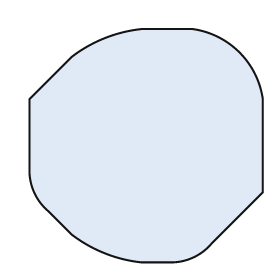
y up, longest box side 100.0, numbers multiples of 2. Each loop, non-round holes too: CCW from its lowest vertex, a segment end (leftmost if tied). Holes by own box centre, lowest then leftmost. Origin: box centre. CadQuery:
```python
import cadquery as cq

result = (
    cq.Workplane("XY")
    .moveTo(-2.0, -50.0)
    .lineTo(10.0, -50.0)
    .threePointArc((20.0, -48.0), (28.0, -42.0))
    .lineTo(50.0, -20.0)
    .lineTo(50.0, 20.0)
    .threePointArc((40.0, 40.0), (20.0, 50.0))
    .lineTo(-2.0, 50.0)
    .threePointArc((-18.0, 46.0), (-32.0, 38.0))
    .lineTo(-50.0, 20.0)
    .lineTo(-50.0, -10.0)
    .threePointArc((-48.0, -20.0), (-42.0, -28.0))
    .lineTo(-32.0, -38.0)
    .threePointArc((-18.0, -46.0), (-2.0, -50.0))
    .close()
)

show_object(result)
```